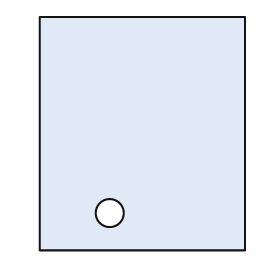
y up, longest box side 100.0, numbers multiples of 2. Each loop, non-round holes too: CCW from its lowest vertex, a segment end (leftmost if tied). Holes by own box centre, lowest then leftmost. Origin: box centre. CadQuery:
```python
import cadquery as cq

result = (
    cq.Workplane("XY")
    .moveTo(-44.0, -50.0)
    .lineTo(44.0, -50.0)
    .lineTo(44.0, 50.0)
    .lineTo(-44.0, 50.0)
    .close()
    .moveTo(-14.0, -34.0)
    .circle(6.0)
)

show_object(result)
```